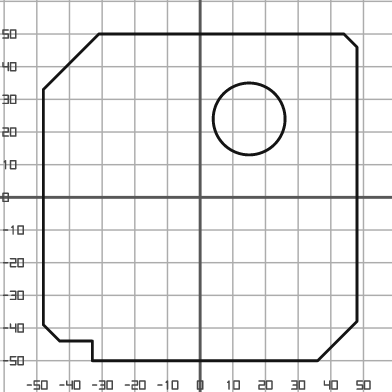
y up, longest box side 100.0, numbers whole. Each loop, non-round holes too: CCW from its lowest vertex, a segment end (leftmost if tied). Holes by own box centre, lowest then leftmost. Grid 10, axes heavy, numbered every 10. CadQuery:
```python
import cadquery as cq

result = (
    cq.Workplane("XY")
    .moveTo(-33.0, -50.0)
    .lineTo(36.0, -50.0)
    .lineTo(48.0, -38.0)
    .lineTo(48.0, 46.0)
    .lineTo(44.0, 50.0)
    .lineTo(-31.0, 50.0)
    .lineTo(-48.0, 33.0)
    .lineTo(-48.0, -39.0)
    .lineTo(-43.0, -44.0)
    .lineTo(-33.0, -44.0)
    .close()
    .moveTo(15.0, 24.0)
    .circle(11.0)
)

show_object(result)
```